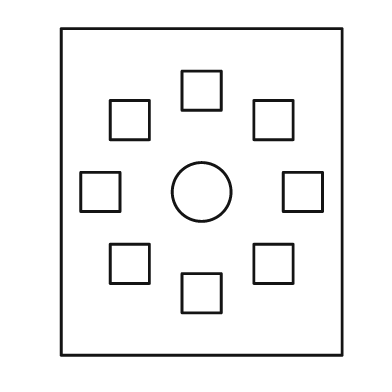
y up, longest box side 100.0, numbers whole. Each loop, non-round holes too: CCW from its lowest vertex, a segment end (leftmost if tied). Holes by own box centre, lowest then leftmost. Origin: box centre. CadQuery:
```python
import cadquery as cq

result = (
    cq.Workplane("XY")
    .moveTo(-43.0, -50.0)
    .lineTo(43.0, -50.0)
    .lineTo(43.0, 50.0)
    .lineTo(-43.0, 50.0)
    .close()
    .moveTo(-6.0, -37.0)
    .lineTo(6.0, -37.0)
    .lineTo(6.0, -25.0)
    .lineTo(-6.0, -25.0)
    .close()
    .moveTo(-28.0, -28.0)
    .lineTo(-16.0, -28.0)
    .lineTo(-16.0, -16.0)
    .lineTo(-28.0, -16.0)
    .close()
    .moveTo(16.0, -28.0)
    .lineTo(28.0, -28.0)
    .lineTo(28.0, -16.0)
    .lineTo(16.0, -16.0)
    .close()
    .moveTo(-37.0, -6.0)
    .lineTo(-25.0, -6.0)
    .lineTo(-25.0, 6.0)
    .lineTo(-37.0, 6.0)
    .close()
    .moveTo(0.0, 0.0)
    .circle(9.0)
    .moveTo(25.0, -6.0)
    .lineTo(37.0, -6.0)
    .lineTo(37.0, 6.0)
    .lineTo(25.0, 6.0)
    .close()
    .moveTo(-28.0, 16.0)
    .lineTo(-16.0, 16.0)
    .lineTo(-16.0, 28.0)
    .lineTo(-28.0, 28.0)
    .close()
    .moveTo(16.0, 16.0)
    .lineTo(28.0, 16.0)
    .lineTo(28.0, 28.0)
    .lineTo(16.0, 28.0)
    .close()
    .moveTo(-6.0, 25.0)
    .lineTo(6.0, 25.0)
    .lineTo(6.0, 37.0)
    .lineTo(-6.0, 37.0)
    .close()
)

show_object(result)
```